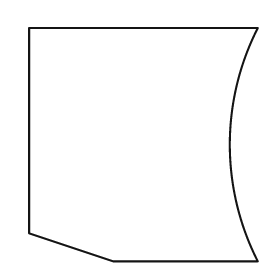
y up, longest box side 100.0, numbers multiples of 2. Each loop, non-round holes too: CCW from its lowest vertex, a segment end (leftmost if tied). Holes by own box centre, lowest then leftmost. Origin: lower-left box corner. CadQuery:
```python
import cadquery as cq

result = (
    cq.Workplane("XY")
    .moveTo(36.0, 0.0)
    .lineTo(98.0, 0.0)
    .threePointArc((86.0, 50.0), (98.0, 100.0))
    .lineTo(0.0, 100.0)
    .lineTo(0.0, 12.0)
    .close()
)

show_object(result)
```